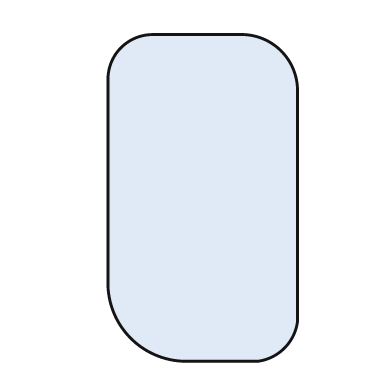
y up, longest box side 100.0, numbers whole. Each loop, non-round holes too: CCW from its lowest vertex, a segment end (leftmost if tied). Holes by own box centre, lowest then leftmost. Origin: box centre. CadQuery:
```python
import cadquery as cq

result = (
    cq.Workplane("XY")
    .moveTo(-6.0, -50.0)
    .lineTo(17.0, -50.0)
    .threePointArc((25.0, -46.0), (29.0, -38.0))
    .lineTo(29.0, 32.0)
    .threePointArc((24.0, 45.0), (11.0, 50.0))
    .lineTo(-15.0, 50.0)
    .threePointArc((-25.0, 46.0), (-29.0, 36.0))
    .lineTo(-29.0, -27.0)
    .threePointArc((-22.0, -43.0), (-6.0, -50.0))
    .close()
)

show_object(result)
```